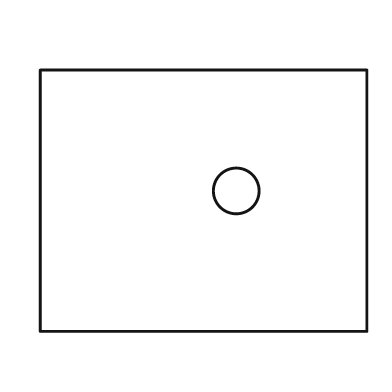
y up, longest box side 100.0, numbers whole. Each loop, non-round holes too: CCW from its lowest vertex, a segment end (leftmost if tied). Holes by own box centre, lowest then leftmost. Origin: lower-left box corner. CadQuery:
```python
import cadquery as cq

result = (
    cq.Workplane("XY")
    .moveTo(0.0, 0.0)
    .lineTo(100.0, 0.0)
    .lineTo(100.0, 80.0)
    .lineTo(0.0, 80.0)
    .close()
    .moveTo(60.0, 43.0)
    .circle(7.0)
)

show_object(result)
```